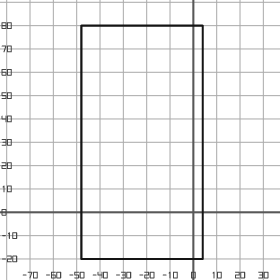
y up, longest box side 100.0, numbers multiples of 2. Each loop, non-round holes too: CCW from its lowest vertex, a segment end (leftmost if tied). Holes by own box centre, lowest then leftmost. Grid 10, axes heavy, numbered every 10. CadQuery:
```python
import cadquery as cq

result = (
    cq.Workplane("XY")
    .moveTo(-48.0, -20.0)
    .lineTo(4.0, -20.0)
    .lineTo(4.0, 80.0)
    .lineTo(-48.0, 80.0)
    .close()
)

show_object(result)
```